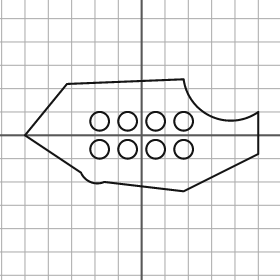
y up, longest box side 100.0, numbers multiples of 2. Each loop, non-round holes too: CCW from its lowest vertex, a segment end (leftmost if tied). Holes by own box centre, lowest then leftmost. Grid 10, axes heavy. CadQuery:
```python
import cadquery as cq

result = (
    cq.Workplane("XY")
    .moveTo(18.0, -24.0)
    .lineTo(50.0, -8.0)
    .lineTo(50.0, 10.0)
    .threePointArc((30.0, 8.0), (18.0, 24.0))
    .lineTo(-32.0, 22.0)
    .lineTo(-50.0, 0.0)
    .lineTo(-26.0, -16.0)
    .threePointArc((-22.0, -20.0), (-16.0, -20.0))
    .close()
    .moveTo(-18.0, -6.0)
    .circle(4.0)
    .moveTo(-6.0, -6.0)
    .circle(4.0)
    .moveTo(6.0, -6.0)
    .circle(4.0)
    .moveTo(18.0, -6.0)
    .circle(4.0)
    .moveTo(-18.0, 6.0)
    .circle(4.0)
    .moveTo(-6.0, 6.0)
    .circle(4.0)
    .moveTo(6.0, 6.0)
    .circle(4.0)
    .moveTo(18.0, 6.0)
    .circle(4.0)
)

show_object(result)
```